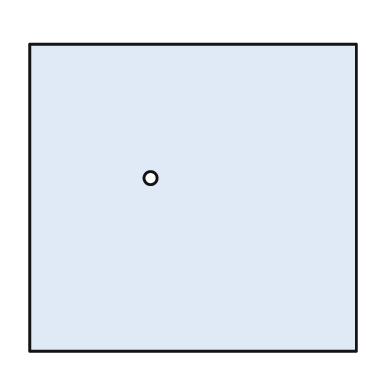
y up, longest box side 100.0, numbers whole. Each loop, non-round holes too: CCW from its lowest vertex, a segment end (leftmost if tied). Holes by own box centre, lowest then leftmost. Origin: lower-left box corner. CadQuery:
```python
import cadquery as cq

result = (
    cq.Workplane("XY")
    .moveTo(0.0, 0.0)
    .lineTo(100.0, 0.0)
    .lineTo(100.0, 94.0)
    .lineTo(0.0, 94.0)
    .close()
    .moveTo(37.0, 53.0)
    .circle(2.0)
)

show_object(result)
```